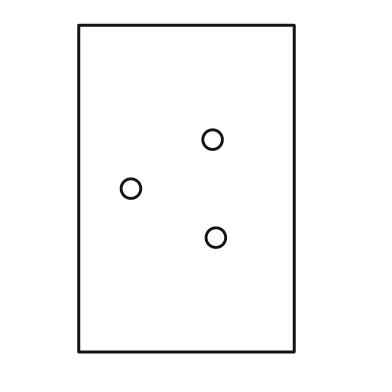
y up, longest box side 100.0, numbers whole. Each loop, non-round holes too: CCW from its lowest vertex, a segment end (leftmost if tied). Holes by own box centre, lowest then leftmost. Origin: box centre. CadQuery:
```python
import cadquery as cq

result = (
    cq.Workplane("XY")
    .moveTo(-33.0, -50.0)
    .lineTo(33.0, -50.0)
    .lineTo(33.0, 50.0)
    .lineTo(-33.0, 50.0)
    .close()
    .moveTo(9.0, -15.0)
    .circle(3.0)
    .moveTo(-17.0, 0.0)
    .circle(3.0)
    .moveTo(8.0, 15.0)
    .circle(3.0)
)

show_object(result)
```